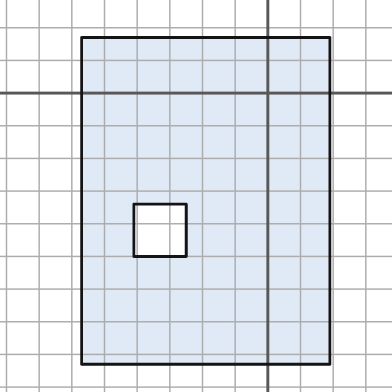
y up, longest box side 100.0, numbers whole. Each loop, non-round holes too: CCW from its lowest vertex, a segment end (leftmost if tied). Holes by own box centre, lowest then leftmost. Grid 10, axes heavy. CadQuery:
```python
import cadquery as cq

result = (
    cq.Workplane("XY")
    .moveTo(-57.0, -83.0)
    .lineTo(19.0, -83.0)
    .lineTo(19.0, 17.0)
    .lineTo(-57.0, 17.0)
    .close()
    .moveTo(-41.0, -50.0)
    .lineTo(-25.0, -50.0)
    .lineTo(-25.0, -34.0)
    .lineTo(-41.0, -34.0)
    .close()
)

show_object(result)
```